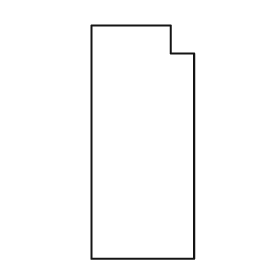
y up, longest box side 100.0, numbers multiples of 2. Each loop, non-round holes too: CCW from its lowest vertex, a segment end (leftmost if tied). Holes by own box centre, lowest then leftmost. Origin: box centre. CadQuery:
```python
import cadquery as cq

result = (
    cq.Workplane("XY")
    .moveTo(-22.0, -50.0)
    .lineTo(22.0, -50.0)
    .lineTo(22.0, 38.0)
    .lineTo(12.0, 38.0)
    .lineTo(12.0, 50.0)
    .lineTo(-22.0, 50.0)
    .close()
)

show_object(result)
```